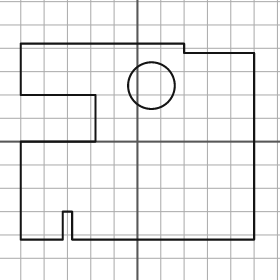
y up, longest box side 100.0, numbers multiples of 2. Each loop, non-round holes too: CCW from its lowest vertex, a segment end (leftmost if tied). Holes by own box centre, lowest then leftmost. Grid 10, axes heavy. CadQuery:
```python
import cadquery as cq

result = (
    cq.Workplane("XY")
    .moveTo(-50.0, -42.0)
    .lineTo(-32.0, -42.0)
    .lineTo(-32.0, -30.0)
    .lineTo(-28.0, -30.0)
    .lineTo(-28.0, -42.0)
    .lineTo(50.0, -42.0)
    .lineTo(50.0, 38.0)
    .lineTo(20.0, 38.0)
    .lineTo(20.0, 42.0)
    .lineTo(-50.0, 42.0)
    .lineTo(-50.0, 20.0)
    .lineTo(-18.0, 20.0)
    .lineTo(-18.0, 0.0)
    .lineTo(-50.0, 0.0)
    .close()
    .moveTo(6.0, 24.0)
    .circle(10.0)
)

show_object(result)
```